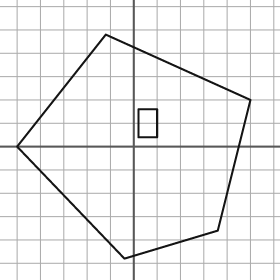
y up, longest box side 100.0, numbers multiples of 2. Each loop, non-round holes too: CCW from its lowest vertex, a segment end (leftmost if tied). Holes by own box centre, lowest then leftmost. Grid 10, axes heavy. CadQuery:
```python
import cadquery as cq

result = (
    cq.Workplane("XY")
    .moveTo(-4.0, -48.0)
    .lineTo(36.0, -36.0)
    .lineTo(50.0, 20.0)
    .lineTo(-12.0, 48.0)
    .lineTo(-50.0, 0.0)
    .close()
    .moveTo(2.0, 4.0)
    .lineTo(10.0, 4.0)
    .lineTo(10.0, 16.0)
    .lineTo(2.0, 16.0)
    .close()
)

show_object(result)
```